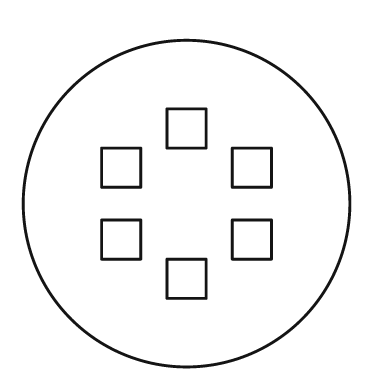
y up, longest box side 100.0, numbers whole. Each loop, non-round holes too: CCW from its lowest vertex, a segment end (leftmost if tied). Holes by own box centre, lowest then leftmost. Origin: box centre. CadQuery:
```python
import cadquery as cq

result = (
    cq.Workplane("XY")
    .moveTo(0.0, 0.0)
    .circle(50.0)
    .moveTo(-6.0, -29.0)
    .lineTo(6.0, -29.0)
    .lineTo(6.0, -17.0)
    .lineTo(-6.0, -17.0)
    .close()
    .moveTo(-26.0, -17.0)
    .lineTo(-14.0, -17.0)
    .lineTo(-14.0, -5.0)
    .lineTo(-26.0, -5.0)
    .close()
    .moveTo(14.0, -17.0)
    .lineTo(26.0, -17.0)
    .lineTo(26.0, -5.0)
    .lineTo(14.0, -5.0)
    .close()
    .moveTo(-26.0, 5.0)
    .lineTo(-14.0, 5.0)
    .lineTo(-14.0, 17.0)
    .lineTo(-26.0, 17.0)
    .close()
    .moveTo(14.0, 5.0)
    .lineTo(26.0, 5.0)
    .lineTo(26.0, 17.0)
    .lineTo(14.0, 17.0)
    .close()
    .moveTo(-6.0, 17.0)
    .lineTo(6.0, 17.0)
    .lineTo(6.0, 29.0)
    .lineTo(-6.0, 29.0)
    .close()
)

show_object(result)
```